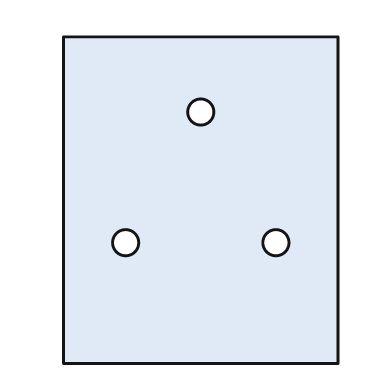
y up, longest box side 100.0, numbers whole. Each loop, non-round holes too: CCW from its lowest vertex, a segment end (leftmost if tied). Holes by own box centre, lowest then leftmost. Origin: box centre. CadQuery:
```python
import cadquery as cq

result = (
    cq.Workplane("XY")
    .moveTo(-42.0, -50.0)
    .lineTo(42.0, -50.0)
    .lineTo(42.0, 50.0)
    .lineTo(-42.0, 50.0)
    .close()
    .moveTo(-23.0, -13.0)
    .circle(4.0)
    .moveTo(23.0, -13.0)
    .circle(4.0)
    .moveTo(0.0, 27.0)
    .circle(4.0)
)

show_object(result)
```